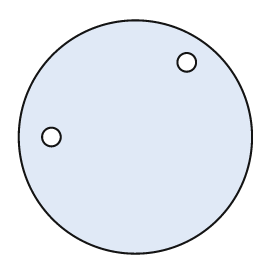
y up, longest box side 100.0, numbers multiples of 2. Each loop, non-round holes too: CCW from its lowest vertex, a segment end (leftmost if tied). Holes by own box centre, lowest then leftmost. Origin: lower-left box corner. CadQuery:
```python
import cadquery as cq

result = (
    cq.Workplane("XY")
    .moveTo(50.0, 50.0)
    .circle(50.0)
    .moveTo(14.0, 50.0)
    .circle(4.0)
    .moveTo(72.0, 82.0)
    .circle(4.0)
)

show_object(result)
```